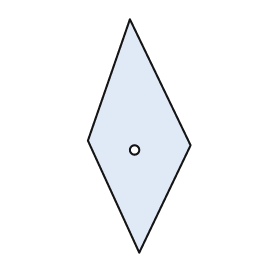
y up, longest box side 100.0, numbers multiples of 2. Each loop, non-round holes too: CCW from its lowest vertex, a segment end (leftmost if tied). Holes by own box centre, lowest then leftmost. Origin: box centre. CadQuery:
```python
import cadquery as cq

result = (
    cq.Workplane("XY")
    .moveTo(0.0, -50.0)
    .lineTo(22.0, -4.0)
    .lineTo(-4.0, 50.0)
    .lineTo(-22.0, -2.0)
    .close()
    .moveTo(-2.0, -6.0)
    .circle(2.0)
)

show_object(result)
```